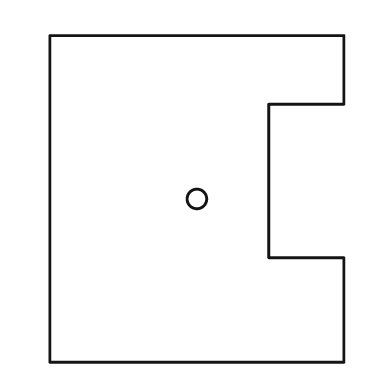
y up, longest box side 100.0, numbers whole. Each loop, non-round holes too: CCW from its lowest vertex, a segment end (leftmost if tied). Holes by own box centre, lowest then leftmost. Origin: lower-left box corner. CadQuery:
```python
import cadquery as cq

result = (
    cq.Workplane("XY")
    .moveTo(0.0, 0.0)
    .lineTo(90.0, 0.0)
    .lineTo(90.0, 32.0)
    .lineTo(67.0, 32.0)
    .lineTo(67.0, 79.0)
    .lineTo(90.0, 79.0)
    .lineTo(90.0, 100.0)
    .lineTo(0.0, 100.0)
    .close()
    .moveTo(45.0, 50.0)
    .circle(3.0)
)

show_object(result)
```